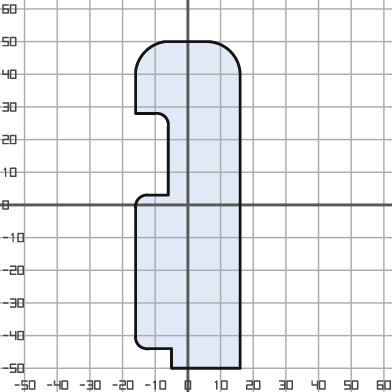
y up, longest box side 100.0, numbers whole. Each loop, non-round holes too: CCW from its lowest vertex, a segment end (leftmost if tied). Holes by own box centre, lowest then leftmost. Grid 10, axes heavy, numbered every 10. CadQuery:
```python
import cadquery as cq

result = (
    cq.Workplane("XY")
    .moveTo(-5.0, -50.0)
    .lineTo(16.0, -50.0)
    .lineTo(16.0, 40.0)
    .threePointArc((13.0, 47.0), (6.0, 50.0))
    .lineTo(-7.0, 50.0)
    .threePointArc((-13.0, 47.0), (-16.0, 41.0))
    .lineTo(-16.0, 28.0)
    .lineTo(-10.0, 28.0)
    .threePointArc((-7.0, 27.0), (-6.0, 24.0))
    .lineTo(-6.0, 3.0)
    .lineTo(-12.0, 3.0)
    .threePointArc((-15.0, 2.0), (-16.0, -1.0))
    .lineTo(-16.0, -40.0)
    .threePointArc((-15.0, -43.0), (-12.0, -44.0))
    .lineTo(-5.0, -44.0)
    .close()
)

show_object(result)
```